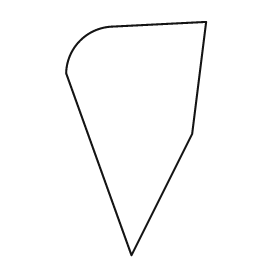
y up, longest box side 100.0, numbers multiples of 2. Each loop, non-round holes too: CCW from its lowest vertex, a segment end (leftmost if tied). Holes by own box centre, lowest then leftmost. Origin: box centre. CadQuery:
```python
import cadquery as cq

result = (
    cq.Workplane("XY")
    .moveTo(-2.0, -50.0)
    .lineTo(24.0, 2.0)
    .lineTo(30.0, 50.0)
    .lineTo(-10.0, 48.0)
    .threePointArc((-24.0, 42.0), (-30.0, 28.0))
    .close()
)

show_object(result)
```